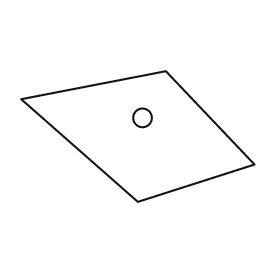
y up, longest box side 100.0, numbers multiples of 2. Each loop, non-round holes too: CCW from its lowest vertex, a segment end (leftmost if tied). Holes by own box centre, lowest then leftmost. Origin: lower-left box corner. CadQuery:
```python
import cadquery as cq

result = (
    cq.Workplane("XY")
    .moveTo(50.0, 0.0)
    .lineTo(100.0, 16.0)
    .lineTo(62.0, 56.0)
    .lineTo(0.0, 44.0)
    .close()
    .moveTo(52.0, 36.0)
    .circle(4.0)
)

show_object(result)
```